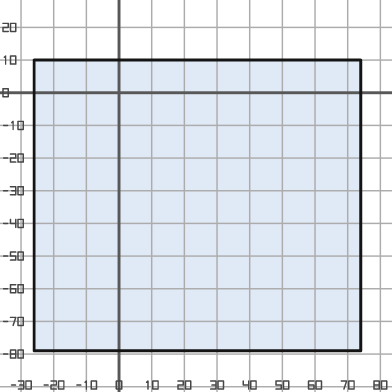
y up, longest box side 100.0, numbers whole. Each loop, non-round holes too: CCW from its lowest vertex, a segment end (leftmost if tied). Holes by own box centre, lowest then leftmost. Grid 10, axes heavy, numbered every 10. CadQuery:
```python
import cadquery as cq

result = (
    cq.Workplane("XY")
    .moveTo(-26.0, -79.0)
    .lineTo(74.0, -79.0)
    .lineTo(74.0, 10.0)
    .lineTo(-26.0, 10.0)
    .close()
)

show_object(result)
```